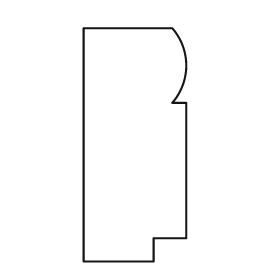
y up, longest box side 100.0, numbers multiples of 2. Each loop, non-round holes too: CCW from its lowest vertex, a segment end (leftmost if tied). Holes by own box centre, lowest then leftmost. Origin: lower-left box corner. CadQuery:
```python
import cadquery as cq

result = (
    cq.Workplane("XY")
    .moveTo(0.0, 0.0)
    .lineTo(30.0, 0.0)
    .lineTo(30.0, 10.0)
    .lineTo(44.0, 10.0)
    .lineTo(44.0, 68.0)
    .lineTo(38.0, 68.0)
    .threePointArc((44.0, 84.0), (38.0, 100.0))
    .lineTo(0.0, 100.0)
    .close()
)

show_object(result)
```